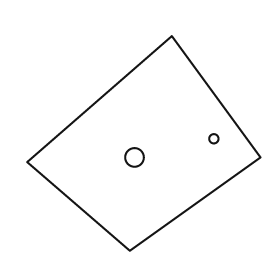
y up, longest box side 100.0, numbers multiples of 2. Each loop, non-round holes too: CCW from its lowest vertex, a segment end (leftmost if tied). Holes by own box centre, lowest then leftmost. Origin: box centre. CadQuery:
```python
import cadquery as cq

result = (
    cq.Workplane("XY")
    .moveTo(-6.0, -46.0)
    .lineTo(50.0, -6.0)
    .lineTo(12.0, 46.0)
    .lineTo(-50.0, -8.0)
    .close()
    .moveTo(-4.0, -6.0)
    .circle(4.0)
    .moveTo(30.0, 2.0)
    .circle(2.0)
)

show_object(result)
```